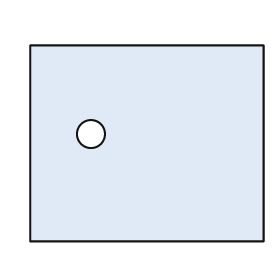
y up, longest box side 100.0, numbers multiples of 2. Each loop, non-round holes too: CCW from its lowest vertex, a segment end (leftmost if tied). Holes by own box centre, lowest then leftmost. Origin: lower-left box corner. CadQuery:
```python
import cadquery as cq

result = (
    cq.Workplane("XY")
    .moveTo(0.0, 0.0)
    .lineTo(100.0, 0.0)
    .lineTo(100.0, 84.0)
    .lineTo(0.0, 84.0)
    .close()
    .moveTo(26.0, 46.0)
    .circle(6.0)
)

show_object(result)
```